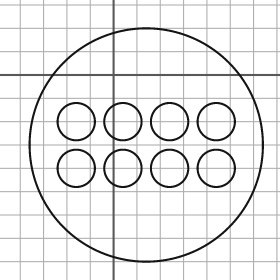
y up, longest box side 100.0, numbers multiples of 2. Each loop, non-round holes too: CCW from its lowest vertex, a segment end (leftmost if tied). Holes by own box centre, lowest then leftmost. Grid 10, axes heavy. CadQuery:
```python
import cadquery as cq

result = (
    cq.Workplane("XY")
    .moveTo(14.0, -30.0)
    .circle(50.0)
    .moveTo(-16.0, -40.0)
    .circle(8.0)
    .moveTo(4.0, -40.0)
    .circle(8.0)
    .moveTo(24.0, -40.0)
    .circle(8.0)
    .moveTo(44.0, -40.0)
    .circle(8.0)
    .moveTo(-16.0, -20.0)
    .circle(8.0)
    .moveTo(4.0, -20.0)
    .circle(8.0)
    .moveTo(24.0, -20.0)
    .circle(8.0)
    .moveTo(44.0, -20.0)
    .circle(8.0)
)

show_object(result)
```